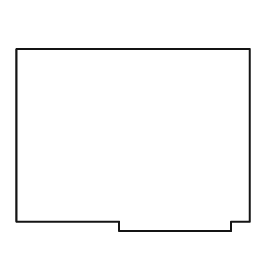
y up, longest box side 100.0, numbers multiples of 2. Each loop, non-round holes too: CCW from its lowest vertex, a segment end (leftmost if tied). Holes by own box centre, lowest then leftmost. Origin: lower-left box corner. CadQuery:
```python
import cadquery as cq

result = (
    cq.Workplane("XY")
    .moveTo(44.0, 0.0)
    .lineTo(92.0, 0.0)
    .lineTo(92.0, 4.0)
    .lineTo(100.0, 4.0)
    .lineTo(100.0, 78.0)
    .lineTo(0.0, 78.0)
    .lineTo(0.0, 4.0)
    .lineTo(44.0, 4.0)
    .close()
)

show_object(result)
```